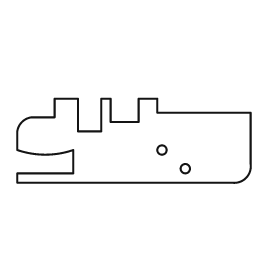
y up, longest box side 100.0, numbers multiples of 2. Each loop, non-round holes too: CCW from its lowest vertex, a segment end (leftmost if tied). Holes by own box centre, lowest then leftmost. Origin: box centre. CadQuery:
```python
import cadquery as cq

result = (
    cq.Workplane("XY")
    .moveTo(-50.0, -18.0)
    .lineTo(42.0, -18.0)
    .threePointArc((48.0, -16.0), (50.0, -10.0))
    .lineTo(50.0, 12.0)
    .lineTo(10.0, 12.0)
    .lineTo(10.0, 18.0)
    .lineTo(2.0, 18.0)
    .lineTo(2.0, 8.0)
    .lineTo(-10.0, 8.0)
    .lineTo(-10.0, 18.0)
    .lineTo(-14.0, 18.0)
    .lineTo(-14.0, 4.0)
    .lineTo(-24.0, 4.0)
    .lineTo(-24.0, 18.0)
    .lineTo(-34.0, 18.0)
    .lineTo(-34.0, 10.0)
    .lineTo(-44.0, 10.0)
    .threePointArc((-48.0, 8.0), (-50.0, 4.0))
    .lineTo(-50.0, -4.0)
    .threePointArc((-38.0, -6.0), (-26.0, -4.0))
    .lineTo(-26.0, -14.0)
    .lineTo(-50.0, -14.0)
    .close()
    .moveTo(22.0, -12.0)
    .circle(2.0)
    .moveTo(12.0, -4.0)
    .circle(2.0)
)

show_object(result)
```